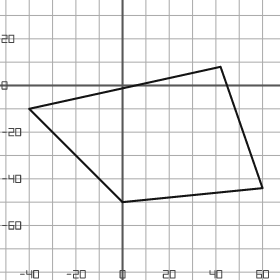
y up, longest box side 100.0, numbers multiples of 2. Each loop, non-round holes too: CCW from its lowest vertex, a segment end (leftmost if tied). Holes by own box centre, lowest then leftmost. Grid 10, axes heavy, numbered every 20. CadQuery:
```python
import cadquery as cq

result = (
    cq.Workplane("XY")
    .moveTo(0.0, -50.0)
    .lineTo(60.0, -44.0)
    .lineTo(42.0, 8.0)
    .lineTo(-40.0, -10.0)
    .close()
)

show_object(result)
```